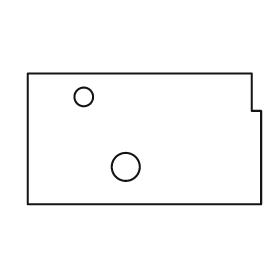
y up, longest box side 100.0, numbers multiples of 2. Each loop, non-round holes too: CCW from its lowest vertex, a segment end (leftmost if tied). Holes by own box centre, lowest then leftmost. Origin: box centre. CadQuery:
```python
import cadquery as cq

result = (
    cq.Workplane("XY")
    .moveTo(-50.0, -28.0)
    .lineTo(50.0, -28.0)
    .lineTo(50.0, 12.0)
    .lineTo(46.0, 12.0)
    .lineTo(46.0, 28.0)
    .lineTo(-50.0, 28.0)
    .close()
    .moveTo(-8.0, -12.0)
    .circle(6.0)
    .moveTo(-26.0, 18.0)
    .circle(4.0)
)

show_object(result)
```